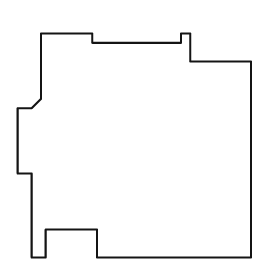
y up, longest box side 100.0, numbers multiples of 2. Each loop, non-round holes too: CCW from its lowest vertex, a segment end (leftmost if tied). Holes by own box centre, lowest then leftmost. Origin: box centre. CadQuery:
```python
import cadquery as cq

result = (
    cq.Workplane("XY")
    .moveTo(-44.0, -48.0)
    .lineTo(-38.0, -48.0)
    .lineTo(-38.0, -36.0)
    .lineTo(-16.0, -36.0)
    .lineTo(-16.0, -48.0)
    .lineTo(50.0, -48.0)
    .lineTo(50.0, 36.0)
    .lineTo(24.0, 36.0)
    .lineTo(24.0, 48.0)
    .lineTo(20.0, 48.0)
    .lineTo(20.0, 44.0)
    .lineTo(-18.0, 44.0)
    .lineTo(-18.0, 48.0)
    .lineTo(-40.0, 48.0)
    .lineTo(-40.0, 20.0)
    .lineTo(-44.0, 16.0)
    .lineTo(-50.0, 16.0)
    .lineTo(-50.0, -12.0)
    .lineTo(-44.0, -12.0)
    .close()
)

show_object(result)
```